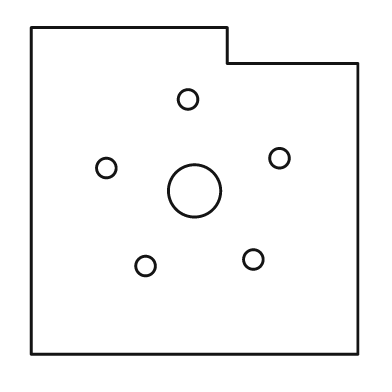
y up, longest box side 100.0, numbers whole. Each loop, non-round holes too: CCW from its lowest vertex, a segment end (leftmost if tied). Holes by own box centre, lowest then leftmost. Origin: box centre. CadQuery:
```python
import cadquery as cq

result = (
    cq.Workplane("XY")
    .moveTo(-50.0, -50.0)
    .lineTo(50.0, -50.0)
    .lineTo(50.0, 39.0)
    .lineTo(10.0, 39.0)
    .lineTo(10.0, 50.0)
    .lineTo(-50.0, 50.0)
    .close()
    .moveTo(-15.0, -23.0)
    .circle(3.0)
    .moveTo(18.0, -21.0)
    .circle(3.0)
    .moveTo(0.0, 0.0)
    .circle(8.0)
    .moveTo(-27.0, 7.0)
    .circle(3.0)
    .moveTo(26.0, 10.0)
    .circle(3.0)
    .moveTo(-2.0, 28.0)
    .circle(3.0)
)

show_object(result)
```